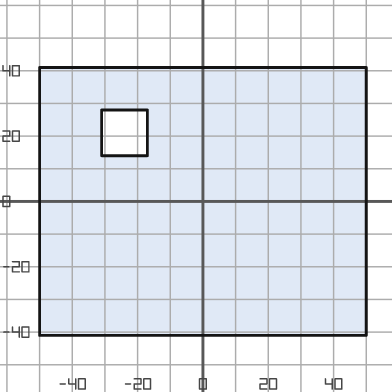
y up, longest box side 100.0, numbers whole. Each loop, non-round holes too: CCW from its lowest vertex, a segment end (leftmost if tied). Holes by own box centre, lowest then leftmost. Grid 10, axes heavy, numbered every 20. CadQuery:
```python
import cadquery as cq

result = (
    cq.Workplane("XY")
    .moveTo(-50.0, -41.0)
    .lineTo(50.0, -41.0)
    .lineTo(50.0, 41.0)
    .lineTo(-50.0, 41.0)
    .close()
    .moveTo(-31.0, 14.0)
    .lineTo(-17.0, 14.0)
    .lineTo(-17.0, 28.0)
    .lineTo(-31.0, 28.0)
    .close()
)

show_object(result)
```